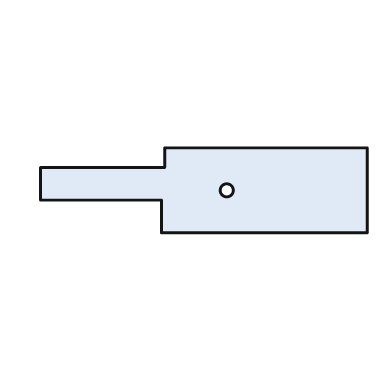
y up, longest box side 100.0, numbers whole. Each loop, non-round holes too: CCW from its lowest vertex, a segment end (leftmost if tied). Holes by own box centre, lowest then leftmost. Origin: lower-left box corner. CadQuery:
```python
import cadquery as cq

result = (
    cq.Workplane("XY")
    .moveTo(37.0, 0.0)
    .lineTo(100.0, 0.0)
    .lineTo(100.0, 26.0)
    .lineTo(38.0, 26.0)
    .lineTo(38.0, 20.0)
    .lineTo(0.0, 20.0)
    .lineTo(0.0, 10.0)
    .lineTo(37.0, 10.0)
    .close()
    .moveTo(57.0, 13.0)
    .circle(2.0)
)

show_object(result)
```